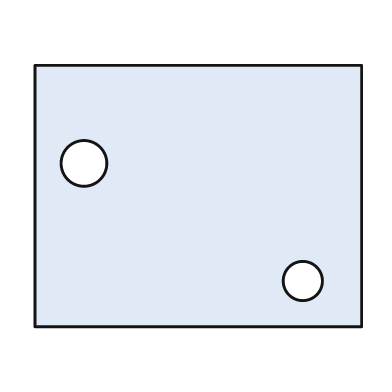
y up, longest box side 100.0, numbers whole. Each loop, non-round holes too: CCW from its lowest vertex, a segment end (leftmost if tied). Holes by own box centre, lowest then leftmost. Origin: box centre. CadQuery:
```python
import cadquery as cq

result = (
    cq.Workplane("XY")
    .moveTo(-50.0, -40.0)
    .lineTo(50.0, -40.0)
    .lineTo(50.0, 40.0)
    .lineTo(-50.0, 40.0)
    .close()
    .moveTo(32.0, -26.0)
    .circle(6.0)
    .moveTo(-35.0, 10.0)
    .circle(7.0)
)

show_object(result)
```